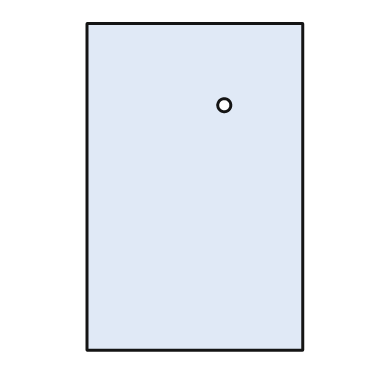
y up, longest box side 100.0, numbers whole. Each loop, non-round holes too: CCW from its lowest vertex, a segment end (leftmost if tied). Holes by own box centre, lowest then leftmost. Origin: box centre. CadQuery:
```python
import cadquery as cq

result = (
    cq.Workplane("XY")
    .moveTo(-33.0, -50.0)
    .lineTo(33.0, -50.0)
    .lineTo(33.0, 50.0)
    .lineTo(-33.0, 50.0)
    .close()
    .moveTo(9.0, 25.0)
    .circle(2.0)
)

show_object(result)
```